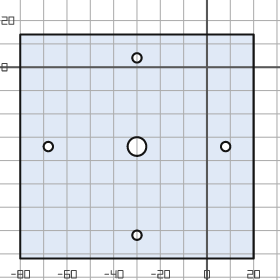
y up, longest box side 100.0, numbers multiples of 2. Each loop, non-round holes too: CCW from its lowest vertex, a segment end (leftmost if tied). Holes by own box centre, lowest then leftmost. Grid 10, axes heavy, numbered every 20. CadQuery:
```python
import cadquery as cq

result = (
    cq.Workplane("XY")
    .moveTo(-80.0, -82.0)
    .lineTo(20.0, -82.0)
    .lineTo(20.0, 14.0)
    .lineTo(-80.0, 14.0)
    .close()
    .moveTo(-30.0, -72.0)
    .circle(2.0)
    .moveTo(-68.0, -34.0)
    .circle(2.0)
    .moveTo(-30.0, -34.0)
    .circle(4.0)
    .moveTo(8.0, -34.0)
    .circle(2.0)
    .moveTo(-30.0, 4.0)
    .circle(2.0)
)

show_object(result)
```